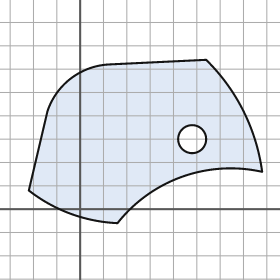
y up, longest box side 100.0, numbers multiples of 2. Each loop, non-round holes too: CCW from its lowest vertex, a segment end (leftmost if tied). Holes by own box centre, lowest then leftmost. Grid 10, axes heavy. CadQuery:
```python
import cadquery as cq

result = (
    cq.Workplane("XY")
    .moveTo(16.0, -6.0)
    .threePointArc((44.0, 14.0), (78.0, 16.0))
    .threePointArc((70.0, 42.0), (54.0, 64.0))
    .lineTo(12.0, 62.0)
    .threePointArc((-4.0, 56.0), (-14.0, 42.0))
    .lineTo(-22.0, 8.0)
    .threePointArc((-4.0, -2.0), (16.0, -6.0))
    .close()
    .moveTo(48.0, 30.0)
    .circle(6.0)
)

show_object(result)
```